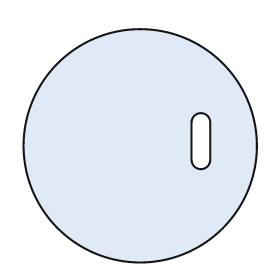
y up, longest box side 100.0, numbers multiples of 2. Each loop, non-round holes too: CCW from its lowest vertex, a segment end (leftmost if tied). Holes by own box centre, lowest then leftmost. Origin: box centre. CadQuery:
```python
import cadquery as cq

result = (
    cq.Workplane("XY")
    .moveTo(0.0, 0.0)
    .circle(50.0)
    .moveTo(22.0, -6.0)
    .threePointArc((26.0, -10.0), (30.0, -6.0))
    .lineTo(30.0, 10.0)
    .threePointArc((26.0, 14.0), (22.0, 10.0))
    .close()
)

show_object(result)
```